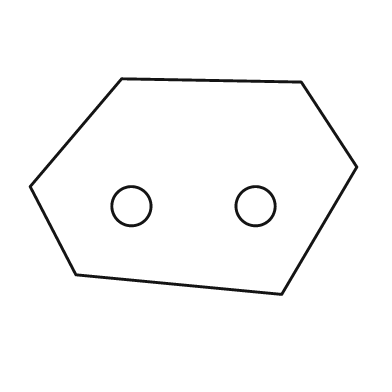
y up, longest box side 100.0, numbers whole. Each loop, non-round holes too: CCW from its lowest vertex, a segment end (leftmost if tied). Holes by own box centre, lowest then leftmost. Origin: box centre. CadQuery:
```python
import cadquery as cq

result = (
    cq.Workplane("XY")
    .moveTo(27.0, -33.0)
    .lineTo(50.0, 6.0)
    .lineTo(33.0, 32.0)
    .lineTo(-22.0, 33.0)
    .lineTo(-50.0, 0.0)
    .lineTo(-36.0, -27.0)
    .close()
    .moveTo(-19.0, -6.0)
    .circle(6.0)
    .moveTo(19.0, -6.0)
    .circle(6.0)
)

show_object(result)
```